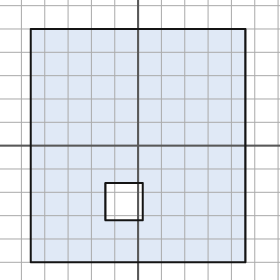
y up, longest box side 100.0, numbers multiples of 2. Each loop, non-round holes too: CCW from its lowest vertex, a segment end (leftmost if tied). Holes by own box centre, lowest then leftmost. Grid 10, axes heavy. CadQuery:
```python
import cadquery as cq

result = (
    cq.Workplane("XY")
    .moveTo(-46.0, -50.0)
    .lineTo(46.0, -50.0)
    .lineTo(46.0, 50.0)
    .lineTo(-46.0, 50.0)
    .close()
    .moveTo(-14.0, -32.0)
    .lineTo(2.0, -32.0)
    .lineTo(2.0, -16.0)
    .lineTo(-14.0, -16.0)
    .close()
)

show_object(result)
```